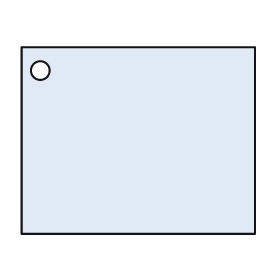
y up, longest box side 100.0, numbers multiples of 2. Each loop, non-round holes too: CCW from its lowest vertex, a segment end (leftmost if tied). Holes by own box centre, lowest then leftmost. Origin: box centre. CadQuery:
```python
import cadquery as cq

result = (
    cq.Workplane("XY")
    .moveTo(-50.0, -40.0)
    .lineTo(50.0, -40.0)
    .lineTo(50.0, 40.0)
    .lineTo(-50.0, 40.0)
    .close()
    .moveTo(-42.0, 30.0)
    .circle(4.0)
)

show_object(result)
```